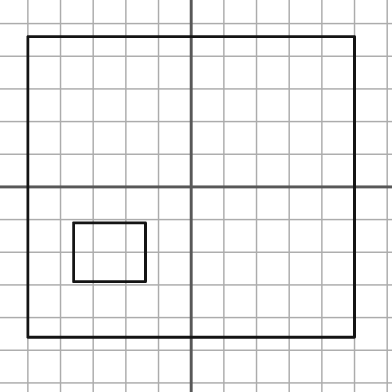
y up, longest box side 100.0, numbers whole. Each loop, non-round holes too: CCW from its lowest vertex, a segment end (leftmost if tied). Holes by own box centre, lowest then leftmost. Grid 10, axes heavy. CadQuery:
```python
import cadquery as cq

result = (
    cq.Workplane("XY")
    .moveTo(-50.0, -46.0)
    .lineTo(50.0, -46.0)
    .lineTo(50.0, 46.0)
    .lineTo(-50.0, 46.0)
    .close()
    .moveTo(-36.0, -29.0)
    .lineTo(-14.0, -29.0)
    .lineTo(-14.0, -11.0)
    .lineTo(-36.0, -11.0)
    .close()
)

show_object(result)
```